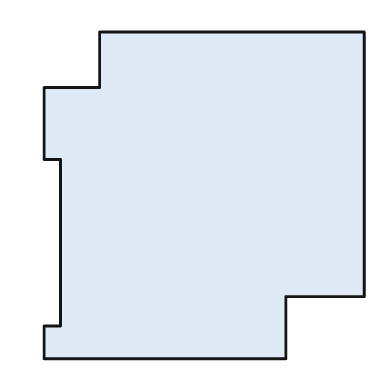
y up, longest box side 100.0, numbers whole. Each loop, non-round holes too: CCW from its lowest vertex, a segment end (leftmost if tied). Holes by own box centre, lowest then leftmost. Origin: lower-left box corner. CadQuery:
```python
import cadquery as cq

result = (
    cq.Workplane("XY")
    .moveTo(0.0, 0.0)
    .lineTo(74.0, 0.0)
    .lineTo(74.0, 19.0)
    .lineTo(98.0, 19.0)
    .lineTo(98.0, 100.0)
    .lineTo(17.0, 100.0)
    .lineTo(17.0, 83.0)
    .lineTo(0.0, 83.0)
    .lineTo(0.0, 61.0)
    .lineTo(5.0, 61.0)
    .lineTo(5.0, 10.0)
    .lineTo(0.0, 10.0)
    .close()
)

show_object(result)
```